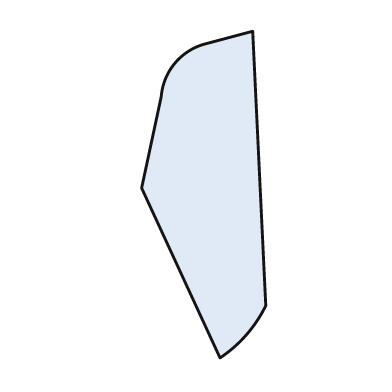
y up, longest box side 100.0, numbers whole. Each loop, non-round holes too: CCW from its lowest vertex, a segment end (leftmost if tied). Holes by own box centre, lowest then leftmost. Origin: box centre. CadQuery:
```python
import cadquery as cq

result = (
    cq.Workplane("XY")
    .moveTo(5.0, -50.0)
    .threePointArc((13.0, -43.0), (19.0, -34.0))
    .lineTo(15.0, 50.0)
    .lineTo(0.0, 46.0)
    .threePointArc((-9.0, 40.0), (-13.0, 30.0))
    .lineTo(-19.0, 2.0)
    .close()
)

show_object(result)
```